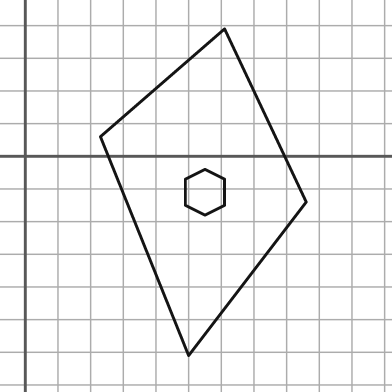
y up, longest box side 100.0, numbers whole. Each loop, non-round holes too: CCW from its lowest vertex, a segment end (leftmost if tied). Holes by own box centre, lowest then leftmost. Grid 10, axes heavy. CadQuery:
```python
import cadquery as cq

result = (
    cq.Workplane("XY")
    .moveTo(50.0, -61.0)
    .lineTo(86.0, -14.0)
    .lineTo(61.0, 39.0)
    .lineTo(23.0, 6.0)
    .close()
    .moveTo(55.0, -18.0)
    .lineTo(61.0, -15.0)
    .lineTo(61.0, -7.0)
    .lineTo(55.0, -4.0)
    .lineTo(49.0, -7.0)
    .lineTo(49.0, -15.0)
    .close()
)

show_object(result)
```